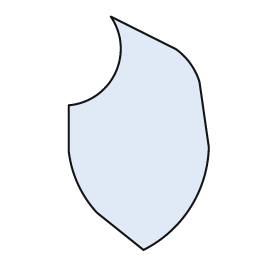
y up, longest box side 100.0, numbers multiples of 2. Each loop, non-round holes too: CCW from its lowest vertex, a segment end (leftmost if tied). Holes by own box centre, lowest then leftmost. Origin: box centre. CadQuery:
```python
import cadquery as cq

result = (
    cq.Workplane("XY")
    .moveTo(2.0, -50.0)
    .threePointArc((22.0, -32.0), (30.0, -6.0))
    .lineTo(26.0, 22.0)
    .threePointArc((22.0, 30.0), (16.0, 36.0))
    .lineTo(-12.0, 50.0)
    .threePointArc((-10.0, 26.0), (-30.0, 12.0))
    .lineTo(-30.0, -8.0)
    .threePointArc((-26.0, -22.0), (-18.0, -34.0))
    .close()
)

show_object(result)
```